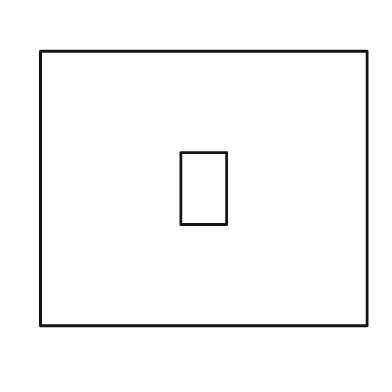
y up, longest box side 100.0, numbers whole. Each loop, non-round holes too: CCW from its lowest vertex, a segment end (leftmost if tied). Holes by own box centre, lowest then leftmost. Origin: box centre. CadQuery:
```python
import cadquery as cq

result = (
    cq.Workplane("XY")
    .moveTo(-50.0, -42.0)
    .lineTo(50.0, -42.0)
    .lineTo(50.0, 42.0)
    .lineTo(-50.0, 42.0)
    .close()
    .moveTo(-7.0, -11.0)
    .lineTo(7.0, -11.0)
    .lineTo(7.0, 11.0)
    .lineTo(-7.0, 11.0)
    .close()
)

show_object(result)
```